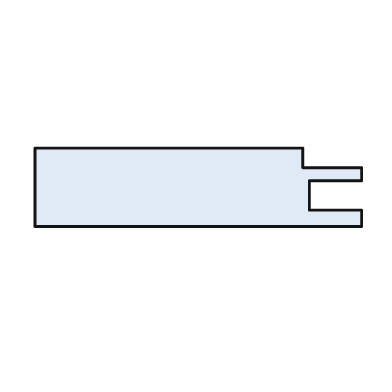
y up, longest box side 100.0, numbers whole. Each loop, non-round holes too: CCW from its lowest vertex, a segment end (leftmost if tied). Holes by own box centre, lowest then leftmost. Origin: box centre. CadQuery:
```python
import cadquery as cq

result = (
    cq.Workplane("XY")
    .moveTo(-50.0, -12.0)
    .lineTo(50.0, -12.0)
    .lineTo(50.0, -7.0)
    .lineTo(34.0, -7.0)
    .lineTo(34.0, 2.0)
    .lineTo(50.0, 2.0)
    .lineTo(50.0, 6.0)
    .lineTo(32.0, 6.0)
    .lineTo(32.0, 12.0)
    .lineTo(-50.0, 12.0)
    .close()
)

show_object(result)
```